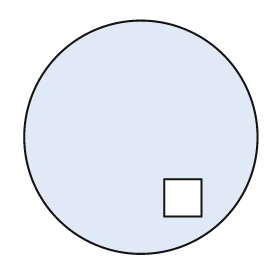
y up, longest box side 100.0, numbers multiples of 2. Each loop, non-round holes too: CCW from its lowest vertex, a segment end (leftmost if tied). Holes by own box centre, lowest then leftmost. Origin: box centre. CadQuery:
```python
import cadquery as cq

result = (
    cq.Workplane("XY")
    .moveTo(0.0, 0.0)
    .circle(50.0)
    .moveTo(10.0, -34.0)
    .lineTo(26.0, -34.0)
    .lineTo(26.0, -18.0)
    .lineTo(10.0, -18.0)
    .close()
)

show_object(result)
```